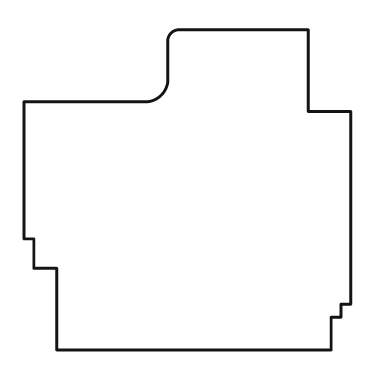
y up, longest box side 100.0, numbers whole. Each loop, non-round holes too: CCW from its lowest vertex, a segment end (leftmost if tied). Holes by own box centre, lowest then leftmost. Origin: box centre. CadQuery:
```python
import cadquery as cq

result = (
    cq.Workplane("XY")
    .moveTo(-40.0, -49.0)
    .lineTo(44.0, -49.0)
    .lineTo(44.0, -39.0)
    .lineTo(47.0, -39.0)
    .lineTo(47.0, -35.0)
    .lineTo(50.0, -35.0)
    .lineTo(50.0, 24.0)
    .lineTo(37.0, 24.0)
    .lineTo(37.0, 49.0)
    .lineTo(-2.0, 49.0)
    .threePointArc((-5.0, 48.0), (-6.0, 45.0))
    .lineTo(-6.0, 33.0)
    .threePointArc((-8.0, 29.0), (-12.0, 27.0))
    .lineTo(-50.0, 27.0)
    .lineTo(-50.0, -15.0)
    .lineTo(-47.0, -15.0)
    .lineTo(-47.0, -24.0)
    .lineTo(-40.0, -24.0)
    .close()
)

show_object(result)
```